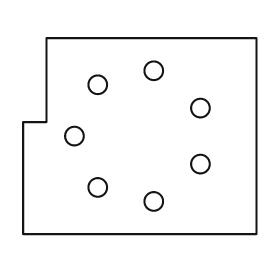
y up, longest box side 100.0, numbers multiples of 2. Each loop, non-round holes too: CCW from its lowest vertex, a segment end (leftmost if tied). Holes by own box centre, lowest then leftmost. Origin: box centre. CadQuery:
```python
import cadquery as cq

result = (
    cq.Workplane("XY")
    .moveTo(-50.0, -42.0)
    .lineTo(50.0, -42.0)
    .lineTo(50.0, 42.0)
    .lineTo(-40.0, 42.0)
    .lineTo(-40.0, 6.0)
    .lineTo(-50.0, 6.0)
    .close()
    .moveTo(6.0, -28.0)
    .circle(4.0)
    .moveTo(-18.0, -22.0)
    .circle(4.0)
    .moveTo(26.0, -12.0)
    .circle(4.0)
    .moveTo(-28.0, 0.0)
    .circle(4.0)
    .moveTo(26.0, 12.0)
    .circle(4.0)
    .moveTo(-18.0, 22.0)
    .circle(4.0)
    .moveTo(6.0, 28.0)
    .circle(4.0)
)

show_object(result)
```